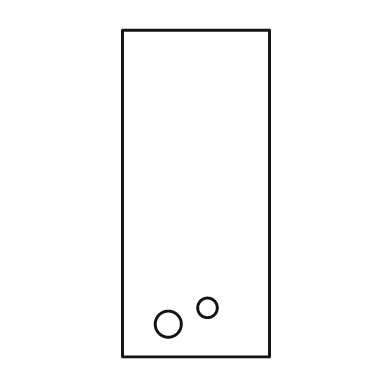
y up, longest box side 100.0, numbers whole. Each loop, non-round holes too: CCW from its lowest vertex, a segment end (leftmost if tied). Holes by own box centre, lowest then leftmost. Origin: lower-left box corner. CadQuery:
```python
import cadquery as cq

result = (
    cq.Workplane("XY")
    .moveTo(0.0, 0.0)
    .lineTo(45.0, 0.0)
    .lineTo(45.0, 100.0)
    .lineTo(0.0, 100.0)
    .close()
    .moveTo(14.0, 10.0)
    .circle(4.0)
    .moveTo(26.0, 15.0)
    .circle(3.0)
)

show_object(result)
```